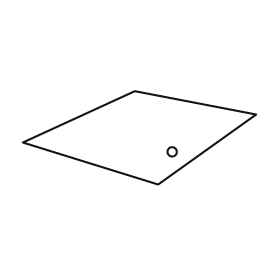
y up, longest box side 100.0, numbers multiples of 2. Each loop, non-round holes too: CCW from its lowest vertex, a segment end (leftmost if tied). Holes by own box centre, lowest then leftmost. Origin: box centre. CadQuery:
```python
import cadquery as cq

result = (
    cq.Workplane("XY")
    .moveTo(8.0, -20.0)
    .lineTo(50.0, 10.0)
    .lineTo(-2.0, 20.0)
    .lineTo(-50.0, -2.0)
    .close()
    .moveTo(14.0, -6.0)
    .circle(2.0)
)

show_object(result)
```